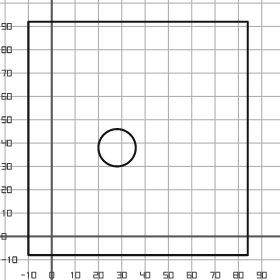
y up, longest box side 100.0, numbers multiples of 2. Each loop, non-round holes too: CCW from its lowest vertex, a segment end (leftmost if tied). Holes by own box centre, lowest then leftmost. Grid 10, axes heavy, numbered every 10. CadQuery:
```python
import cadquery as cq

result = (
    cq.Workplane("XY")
    .moveTo(-10.0, -8.0)
    .lineTo(84.0, -8.0)
    .lineTo(84.0, 92.0)
    .lineTo(-10.0, 92.0)
    .close()
    .moveTo(28.0, 38.0)
    .circle(8.0)
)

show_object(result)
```